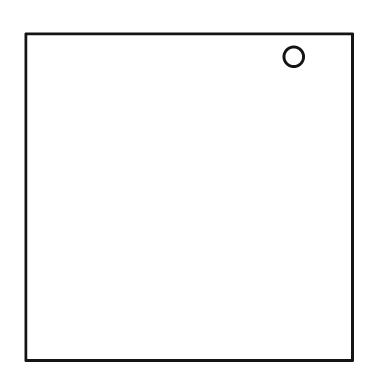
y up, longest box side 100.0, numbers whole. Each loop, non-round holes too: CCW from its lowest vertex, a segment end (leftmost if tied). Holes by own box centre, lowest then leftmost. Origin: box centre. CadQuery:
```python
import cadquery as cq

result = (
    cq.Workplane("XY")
    .moveTo(-50.0, -50.0)
    .lineTo(50.0, -50.0)
    .lineTo(50.0, 50.0)
    .lineTo(-50.0, 50.0)
    .close()
    .moveTo(32.0, 43.0)
    .circle(3.0)
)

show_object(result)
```